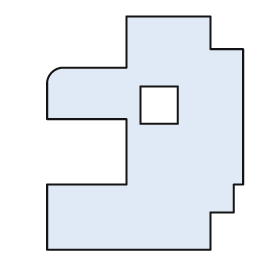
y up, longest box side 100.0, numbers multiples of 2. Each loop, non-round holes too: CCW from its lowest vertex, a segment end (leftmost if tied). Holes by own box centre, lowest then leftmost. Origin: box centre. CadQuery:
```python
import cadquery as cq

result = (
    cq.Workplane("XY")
    .moveTo(-42.0, -50.0)
    .lineTo(28.0, -50.0)
    .lineTo(28.0, -34.0)
    .lineTo(38.0, -34.0)
    .lineTo(38.0, -22.0)
    .lineTo(42.0, -22.0)
    .lineTo(42.0, 36.0)
    .lineTo(28.0, 36.0)
    .lineTo(28.0, 50.0)
    .lineTo(-8.0, 50.0)
    .lineTo(-8.0, 28.0)
    .lineTo(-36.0, 28.0)
    .threePointArc((-40.0, 26.0), (-42.0, 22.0))
    .lineTo(-42.0, 6.0)
    .lineTo(-8.0, 6.0)
    .lineTo(-8.0, -22.0)
    .lineTo(-42.0, -22.0)
    .close()
    .moveTo(-2.0, 4.0)
    .lineTo(14.0, 4.0)
    .lineTo(14.0, 20.0)
    .lineTo(-2.0, 20.0)
    .close()
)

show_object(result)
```